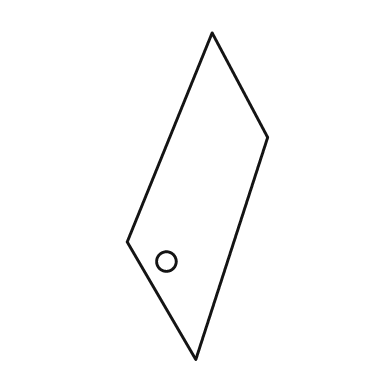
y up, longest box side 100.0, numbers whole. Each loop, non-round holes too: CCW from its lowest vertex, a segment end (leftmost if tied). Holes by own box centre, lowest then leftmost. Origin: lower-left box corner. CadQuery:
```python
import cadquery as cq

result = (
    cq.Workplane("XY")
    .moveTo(21.0, 0.0)
    .lineTo(43.0, 68.0)
    .lineTo(26.0, 100.0)
    .lineTo(0.0, 36.0)
    .close()
    .moveTo(12.0, 30.0)
    .circle(3.0)
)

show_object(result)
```